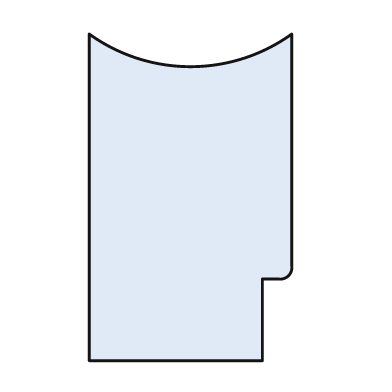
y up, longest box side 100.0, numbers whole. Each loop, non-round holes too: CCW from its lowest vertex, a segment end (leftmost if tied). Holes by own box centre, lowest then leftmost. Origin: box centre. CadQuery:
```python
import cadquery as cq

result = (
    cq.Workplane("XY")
    .moveTo(-31.0, -50.0)
    .lineTo(22.0, -50.0)
    .lineTo(22.0, -25.0)
    .lineTo(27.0, -25.0)
    .threePointArc((30.0, -24.0), (31.0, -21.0))
    .lineTo(31.0, 50.0)
    .threePointArc((0.0, 40.0), (-31.0, 50.0))
    .close()
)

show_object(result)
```